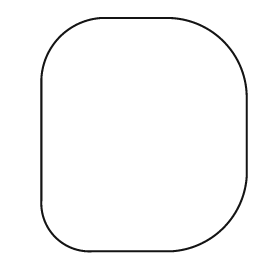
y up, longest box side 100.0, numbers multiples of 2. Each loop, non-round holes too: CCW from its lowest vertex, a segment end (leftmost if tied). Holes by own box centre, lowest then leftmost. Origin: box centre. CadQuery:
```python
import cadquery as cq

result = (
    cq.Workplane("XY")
    .moveTo(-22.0, -50.0)
    .lineTo(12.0, -50.0)
    .threePointArc((34.0, -40.0), (44.0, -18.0))
    .lineTo(44.0, 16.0)
    .threePointArc((34.0, 40.0), (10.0, 50.0))
    .lineTo(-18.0, 50.0)
    .threePointArc((-36.0, 42.0), (-44.0, 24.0))
    .lineTo(-44.0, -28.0)
    .threePointArc((-38.0, -44.0), (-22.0, -50.0))
    .close()
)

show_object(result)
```